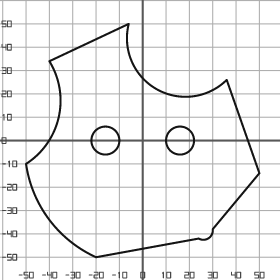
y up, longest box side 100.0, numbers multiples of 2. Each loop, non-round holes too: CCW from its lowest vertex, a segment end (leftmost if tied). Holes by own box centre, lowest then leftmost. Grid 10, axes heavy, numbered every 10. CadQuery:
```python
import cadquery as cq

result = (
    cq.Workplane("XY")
    .moveTo(-20.0, -50.0)
    .lineTo(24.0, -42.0)
    .threePointArc((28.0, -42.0), (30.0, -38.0))
    .lineTo(50.0, -14.0)
    .lineTo(36.0, 26.0)
    .threePointArc((6.0, 22.0), (-6.0, 50.0))
    .lineTo(-40.0, 34.0)
    .threePointArc((-36.0, 10.0), (-50.0, -10.0))
    .threePointArc((-40.0, -34.0), (-20.0, -50.0))
    .close()
    .moveTo(-16.0, 0.0)
    .circle(6.0)
    .moveTo(16.0, 0.0)
    .circle(6.0)
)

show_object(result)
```